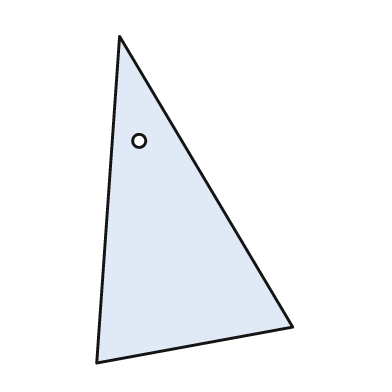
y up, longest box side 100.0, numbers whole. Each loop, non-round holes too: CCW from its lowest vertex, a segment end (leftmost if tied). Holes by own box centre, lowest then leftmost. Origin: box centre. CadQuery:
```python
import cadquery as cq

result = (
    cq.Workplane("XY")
    .moveTo(-30.0, -50.0)
    .lineTo(30.0, -39.0)
    .lineTo(-23.0, 50.0)
    .close()
    .moveTo(-17.0, 18.0)
    .circle(2.0)
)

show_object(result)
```